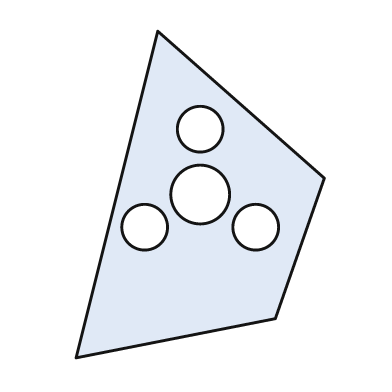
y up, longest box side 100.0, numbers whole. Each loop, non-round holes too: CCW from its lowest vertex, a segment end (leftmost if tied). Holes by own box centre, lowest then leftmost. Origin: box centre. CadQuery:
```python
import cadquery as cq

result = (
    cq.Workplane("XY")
    .moveTo(-38.0, -50.0)
    .lineTo(23.0, -38.0)
    .lineTo(38.0, 5.0)
    .lineTo(-13.0, 50.0)
    .close()
    .moveTo(-17.0, -10.0)
    .circle(7.0)
    .moveTo(17.0, -10.0)
    .circle(7.0)
    .moveTo(0.0, 0.0)
    .circle(9.0)
    .moveTo(0.0, 20.0)
    .circle(7.0)
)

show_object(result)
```